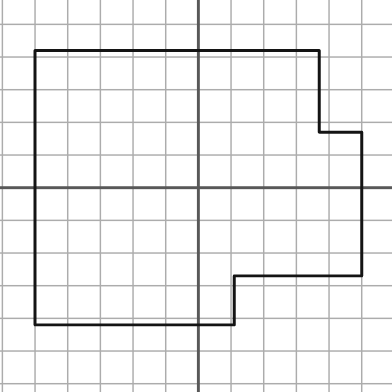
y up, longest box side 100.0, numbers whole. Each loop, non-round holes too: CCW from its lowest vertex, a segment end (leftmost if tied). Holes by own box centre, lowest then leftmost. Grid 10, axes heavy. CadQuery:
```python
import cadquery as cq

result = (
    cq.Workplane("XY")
    .moveTo(-50.0, -42.0)
    .lineTo(11.0, -42.0)
    .lineTo(11.0, -27.0)
    .lineTo(50.0, -27.0)
    .lineTo(50.0, 17.0)
    .lineTo(37.0, 17.0)
    .lineTo(37.0, 42.0)
    .lineTo(-50.0, 42.0)
    .close()
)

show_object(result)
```